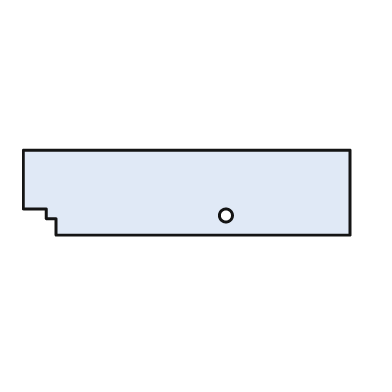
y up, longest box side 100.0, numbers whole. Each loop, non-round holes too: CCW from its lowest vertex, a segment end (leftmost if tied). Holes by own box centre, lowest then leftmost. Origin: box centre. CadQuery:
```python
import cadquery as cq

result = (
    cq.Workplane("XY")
    .moveTo(-40.0, -13.0)
    .lineTo(50.0, -13.0)
    .lineTo(50.0, 13.0)
    .lineTo(-50.0, 13.0)
    .lineTo(-50.0, -5.0)
    .lineTo(-43.0, -5.0)
    .lineTo(-43.0, -8.0)
    .lineTo(-40.0, -8.0)
    .close()
    .moveTo(12.0, -7.0)
    .circle(2.0)
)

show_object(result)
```